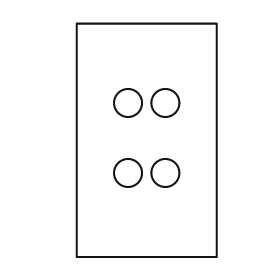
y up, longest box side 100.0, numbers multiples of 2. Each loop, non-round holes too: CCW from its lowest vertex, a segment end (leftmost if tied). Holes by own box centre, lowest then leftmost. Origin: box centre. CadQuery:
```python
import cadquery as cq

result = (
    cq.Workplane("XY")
    .moveTo(-30.0, -50.0)
    .lineTo(30.0, -50.0)
    .lineTo(30.0, 50.0)
    .lineTo(-30.0, 50.0)
    .close()
    .moveTo(-8.0, -14.0)
    .circle(6.0)
    .moveTo(8.0, -14.0)
    .circle(6.0)
    .moveTo(-8.0, 16.0)
    .circle(6.0)
    .moveTo(8.0, 16.0)
    .circle(6.0)
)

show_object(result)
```